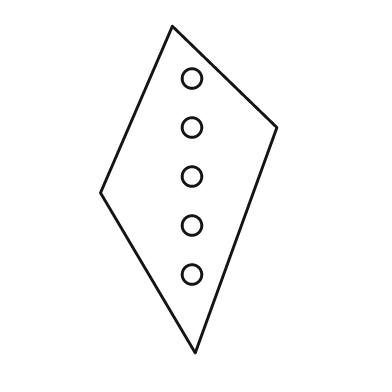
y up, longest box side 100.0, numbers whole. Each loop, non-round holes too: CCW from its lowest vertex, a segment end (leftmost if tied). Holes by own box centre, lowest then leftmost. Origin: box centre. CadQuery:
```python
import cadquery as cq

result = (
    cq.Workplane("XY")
    .moveTo(2.0, -50.0)
    .lineTo(27.0, 19.0)
    .lineTo(-5.0, 50.0)
    .lineTo(-27.0, -1.0)
    .close()
    .moveTo(1.0, -26.0)
    .circle(3.0)
    .moveTo(1.0, -11.0)
    .circle(3.0)
    .moveTo(1.0, 4.0)
    .circle(3.0)
    .moveTo(1.0, 19.0)
    .circle(3.0)
    .moveTo(1.0, 34.0)
    .circle(3.0)
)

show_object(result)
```